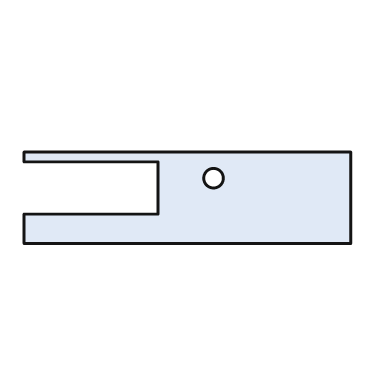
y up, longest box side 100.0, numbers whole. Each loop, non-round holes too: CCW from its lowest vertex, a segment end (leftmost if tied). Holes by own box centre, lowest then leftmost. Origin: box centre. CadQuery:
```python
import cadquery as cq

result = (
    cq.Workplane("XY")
    .moveTo(-50.0, -14.0)
    .lineTo(50.0, -14.0)
    .lineTo(50.0, 14.0)
    .lineTo(-50.0, 14.0)
    .lineTo(-50.0, 11.0)
    .lineTo(-9.0, 11.0)
    .lineTo(-9.0, -5.0)
    .lineTo(-50.0, -5.0)
    .close()
    .moveTo(8.0, 6.0)
    .circle(3.0)
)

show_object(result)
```